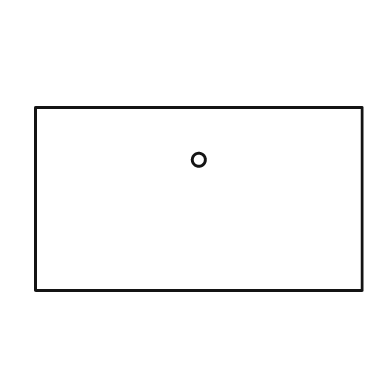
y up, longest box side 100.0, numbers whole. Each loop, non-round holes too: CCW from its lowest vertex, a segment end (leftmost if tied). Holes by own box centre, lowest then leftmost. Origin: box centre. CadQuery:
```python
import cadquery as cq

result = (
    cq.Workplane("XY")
    .moveTo(-50.0, -28.0)
    .lineTo(50.0, -28.0)
    .lineTo(50.0, 28.0)
    .lineTo(-50.0, 28.0)
    .close()
    .moveTo(0.0, 12.0)
    .circle(2.0)
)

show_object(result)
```